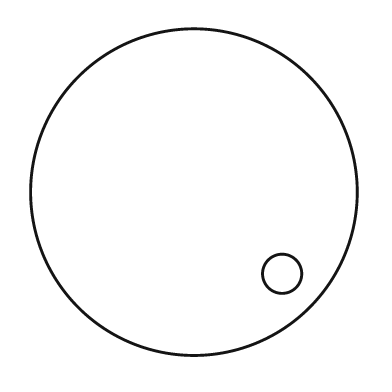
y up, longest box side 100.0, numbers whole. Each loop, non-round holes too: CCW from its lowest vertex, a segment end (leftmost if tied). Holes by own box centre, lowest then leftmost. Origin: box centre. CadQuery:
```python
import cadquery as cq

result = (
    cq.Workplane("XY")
    .moveTo(0.0, 0.0)
    .circle(50.0)
    .moveTo(27.0, -25.0)
    .circle(6.0)
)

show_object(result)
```